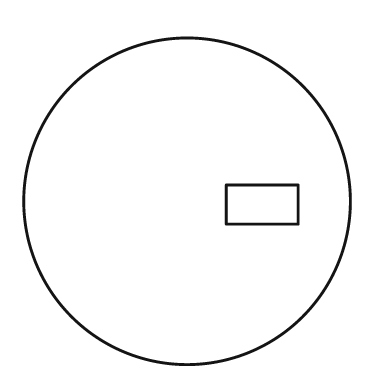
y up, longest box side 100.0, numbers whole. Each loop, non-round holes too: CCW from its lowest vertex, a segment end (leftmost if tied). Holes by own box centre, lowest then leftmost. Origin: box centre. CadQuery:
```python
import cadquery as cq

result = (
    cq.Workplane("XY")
    .moveTo(0.0, 0.0)
    .circle(50.0)
    .moveTo(12.0, -7.0)
    .lineTo(34.0, -7.0)
    .lineTo(34.0, 5.0)
    .lineTo(12.0, 5.0)
    .close()
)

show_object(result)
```